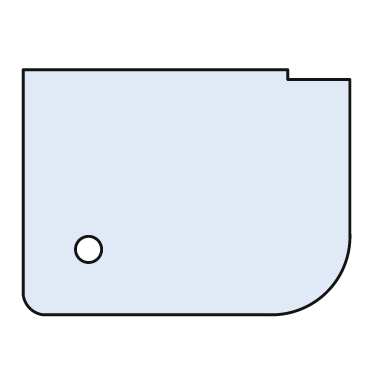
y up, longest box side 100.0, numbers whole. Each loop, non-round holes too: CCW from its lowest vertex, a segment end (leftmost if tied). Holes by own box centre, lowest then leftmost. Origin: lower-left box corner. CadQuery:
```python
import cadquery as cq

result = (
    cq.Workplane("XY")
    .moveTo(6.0, 0.0)
    .lineTo(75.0, 0.0)
    .threePointArc((93.0, 7.0), (100.0, 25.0))
    .lineTo(100.0, 72.0)
    .lineTo(81.0, 72.0)
    .lineTo(81.0, 75.0)
    .lineTo(0.0, 75.0)
    .lineTo(0.0, 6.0)
    .threePointArc((2.0, 2.0), (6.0, 0.0))
    .close()
    .moveTo(20.0, 20.0)
    .circle(4.0)
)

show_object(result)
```